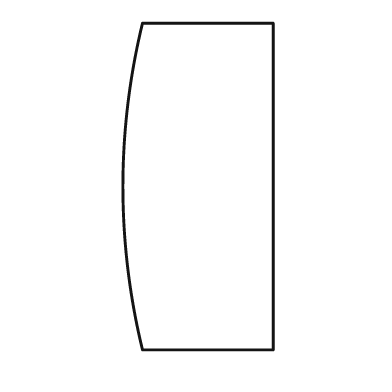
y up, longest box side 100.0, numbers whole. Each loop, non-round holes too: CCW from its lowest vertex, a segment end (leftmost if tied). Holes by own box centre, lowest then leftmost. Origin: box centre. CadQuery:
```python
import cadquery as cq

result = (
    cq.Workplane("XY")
    .moveTo(-17.0, -50.0)
    .lineTo(23.0, -50.0)
    .lineTo(23.0, 50.0)
    .lineTo(-17.0, 50.0)
    .threePointArc((-23.0, 0.0), (-17.0, -50.0))
    .close()
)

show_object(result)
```